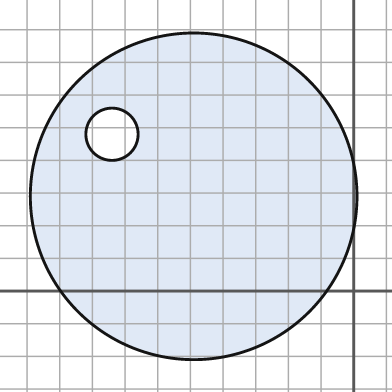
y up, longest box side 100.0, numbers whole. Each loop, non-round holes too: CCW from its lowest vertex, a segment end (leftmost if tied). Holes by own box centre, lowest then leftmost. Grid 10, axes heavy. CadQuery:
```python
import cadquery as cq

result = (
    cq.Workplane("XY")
    .moveTo(-49.0, 29.0)
    .circle(50.0)
    .moveTo(-74.0, 48.0)
    .circle(8.0)
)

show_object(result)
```